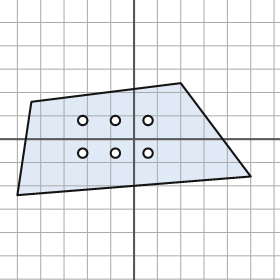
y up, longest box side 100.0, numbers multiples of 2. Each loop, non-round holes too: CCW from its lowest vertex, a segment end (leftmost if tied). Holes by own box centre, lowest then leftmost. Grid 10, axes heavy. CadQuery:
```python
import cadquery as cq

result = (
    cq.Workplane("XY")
    .moveTo(-50.0, -24.0)
    .lineTo(50.0, -16.0)
    .lineTo(20.0, 24.0)
    .lineTo(-44.0, 16.0)
    .close()
    .moveTo(-22.0, -6.0)
    .circle(2.0)
    .moveTo(-8.0, -6.0)
    .circle(2.0)
    .moveTo(6.0, -6.0)
    .circle(2.0)
    .moveTo(-22.0, 8.0)
    .circle(2.0)
    .moveTo(-8.0, 8.0)
    .circle(2.0)
    .moveTo(6.0, 8.0)
    .circle(2.0)
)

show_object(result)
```